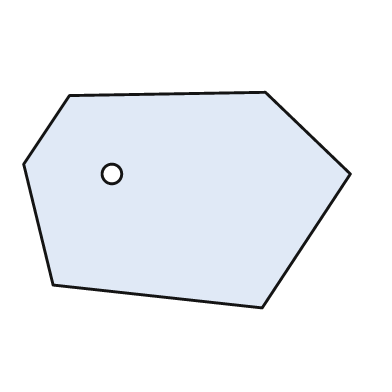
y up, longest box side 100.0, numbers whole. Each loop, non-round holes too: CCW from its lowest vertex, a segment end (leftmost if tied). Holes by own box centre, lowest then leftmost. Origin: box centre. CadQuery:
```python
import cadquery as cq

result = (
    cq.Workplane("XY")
    .moveTo(23.0, -33.0)
    .lineTo(50.0, 8.0)
    .lineTo(24.0, 33.0)
    .lineTo(-36.0, 32.0)
    .lineTo(-50.0, 11.0)
    .lineTo(-41.0, -26.0)
    .close()
    .moveTo(-23.0, 8.0)
    .circle(3.0)
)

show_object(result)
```